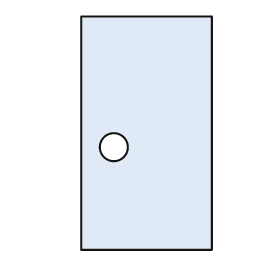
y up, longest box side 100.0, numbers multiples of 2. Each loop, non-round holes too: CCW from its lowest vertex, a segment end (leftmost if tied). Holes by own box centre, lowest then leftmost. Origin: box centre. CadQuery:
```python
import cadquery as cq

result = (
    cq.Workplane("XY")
    .moveTo(-28.0, -50.0)
    .lineTo(28.0, -50.0)
    .lineTo(28.0, 50.0)
    .lineTo(-28.0, 50.0)
    .close()
    .moveTo(-14.0, -6.0)
    .circle(6.0)
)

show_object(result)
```